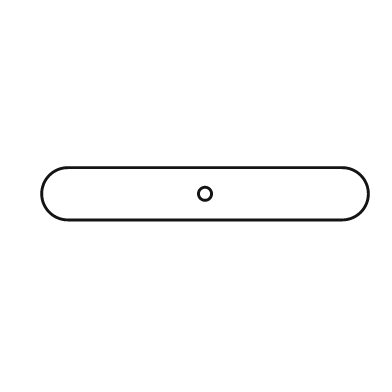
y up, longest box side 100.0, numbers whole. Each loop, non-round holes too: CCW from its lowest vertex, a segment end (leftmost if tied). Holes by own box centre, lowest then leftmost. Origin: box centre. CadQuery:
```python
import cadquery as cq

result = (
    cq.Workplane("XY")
    .moveTo(-42.0, -8.0)
    .lineTo(42.0, -8.0)
    .threePointArc((50.0, 0.0), (42.0, 8.0))
    .lineTo(-42.0, 8.0)
    .threePointArc((-50.0, 0.0), (-42.0, -8.0))
    .close()
    .moveTo(0.0, 0.0)
    .circle(2.0)
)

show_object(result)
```